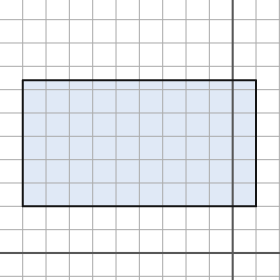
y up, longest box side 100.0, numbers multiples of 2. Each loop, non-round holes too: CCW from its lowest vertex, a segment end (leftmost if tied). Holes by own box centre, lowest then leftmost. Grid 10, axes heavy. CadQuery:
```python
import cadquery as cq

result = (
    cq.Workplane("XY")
    .moveTo(-90.0, 20.0)
    .lineTo(10.0, 20.0)
    .lineTo(10.0, 74.0)
    .lineTo(-90.0, 74.0)
    .close()
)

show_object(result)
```